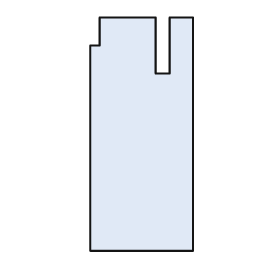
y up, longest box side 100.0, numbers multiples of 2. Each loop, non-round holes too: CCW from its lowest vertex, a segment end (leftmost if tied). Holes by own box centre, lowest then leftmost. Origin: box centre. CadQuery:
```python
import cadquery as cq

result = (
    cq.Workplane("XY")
    .moveTo(-22.0, -50.0)
    .lineTo(22.0, -50.0)
    .lineTo(22.0, 50.0)
    .lineTo(12.0, 50.0)
    .lineTo(12.0, 26.0)
    .lineTo(6.0, 26.0)
    .lineTo(6.0, 50.0)
    .lineTo(-18.0, 50.0)
    .lineTo(-18.0, 38.0)
    .lineTo(-22.0, 38.0)
    .close()
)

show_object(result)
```